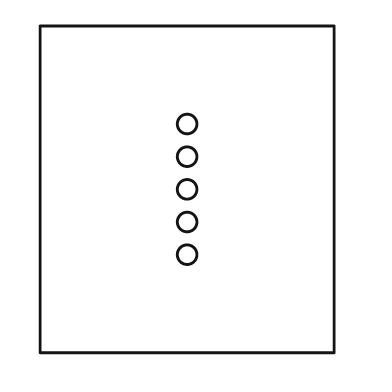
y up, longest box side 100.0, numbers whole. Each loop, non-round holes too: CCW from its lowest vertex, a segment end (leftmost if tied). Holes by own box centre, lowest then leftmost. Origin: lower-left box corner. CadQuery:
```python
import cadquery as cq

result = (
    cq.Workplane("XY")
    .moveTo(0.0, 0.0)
    .lineTo(90.0, 0.0)
    .lineTo(90.0, 100.0)
    .lineTo(0.0, 100.0)
    .close()
    .moveTo(45.0, 30.0)
    .circle(3.0)
    .moveTo(45.0, 40.0)
    .circle(3.0)
    .moveTo(45.0, 50.0)
    .circle(3.0)
    .moveTo(45.0, 60.0)
    .circle(3.0)
    .moveTo(45.0, 70.0)
    .circle(3.0)
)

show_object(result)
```